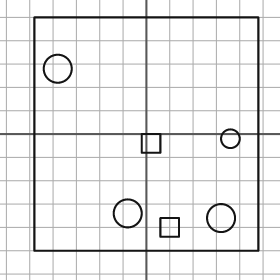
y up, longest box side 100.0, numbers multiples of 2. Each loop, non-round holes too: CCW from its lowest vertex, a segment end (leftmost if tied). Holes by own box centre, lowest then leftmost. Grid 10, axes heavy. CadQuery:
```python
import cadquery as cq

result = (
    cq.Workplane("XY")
    .moveTo(-48.0, -50.0)
    .lineTo(48.0, -50.0)
    .lineTo(48.0, 50.0)
    .lineTo(-48.0, 50.0)
    .close()
    .moveTo(6.0, -44.0)
    .lineTo(14.0, -44.0)
    .lineTo(14.0, -36.0)
    .lineTo(6.0, -36.0)
    .close()
    .moveTo(32.0, -36.0)
    .circle(6.0)
    .moveTo(-8.0, -34.0)
    .circle(6.0)
    .moveTo(-2.0, -8.0)
    .lineTo(6.0, -8.0)
    .lineTo(6.0, 0.0)
    .lineTo(-2.0, 0.0)
    .close()
    .moveTo(36.0, -2.0)
    .circle(4.0)
    .moveTo(-38.0, 28.0)
    .circle(6.0)
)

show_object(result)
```